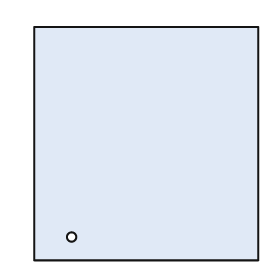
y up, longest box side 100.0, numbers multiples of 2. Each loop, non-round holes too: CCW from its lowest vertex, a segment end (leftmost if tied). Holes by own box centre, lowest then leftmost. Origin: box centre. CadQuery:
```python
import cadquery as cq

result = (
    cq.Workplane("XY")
    .moveTo(-48.0, -50.0)
    .lineTo(48.0, -50.0)
    .lineTo(48.0, 50.0)
    .lineTo(-48.0, 50.0)
    .close()
    .moveTo(-32.0, -40.0)
    .circle(2.0)
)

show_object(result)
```